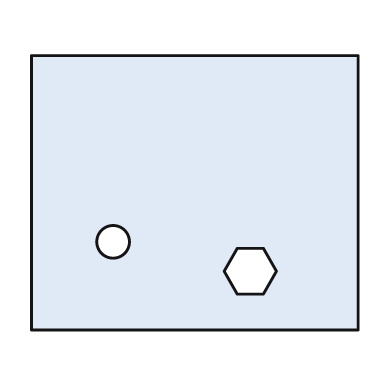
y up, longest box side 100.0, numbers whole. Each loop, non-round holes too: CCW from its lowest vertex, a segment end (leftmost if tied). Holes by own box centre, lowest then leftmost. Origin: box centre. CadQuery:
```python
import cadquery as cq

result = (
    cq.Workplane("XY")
    .moveTo(-50.0, -42.0)
    .lineTo(50.0, -42.0)
    .lineTo(50.0, 42.0)
    .lineTo(-50.0, 42.0)
    .close()
    .moveTo(13.0, -31.0)
    .lineTo(21.0, -31.0)
    .lineTo(25.0, -24.0)
    .lineTo(21.0, -17.0)
    .lineTo(13.0, -17.0)
    .lineTo(9.0, -24.0)
    .close()
    .moveTo(-25.0, -15.0)
    .circle(5.0)
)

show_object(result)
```